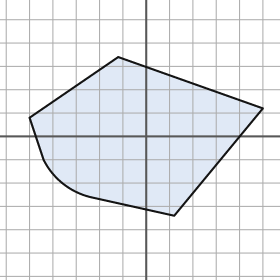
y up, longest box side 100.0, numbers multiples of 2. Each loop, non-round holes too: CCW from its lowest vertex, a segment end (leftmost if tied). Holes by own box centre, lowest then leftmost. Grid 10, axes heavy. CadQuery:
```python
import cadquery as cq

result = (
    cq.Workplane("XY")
    .moveTo(12.0, -34.0)
    .lineTo(50.0, 12.0)
    .lineTo(-12.0, 34.0)
    .lineTo(-50.0, 8.0)
    .lineTo(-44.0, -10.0)
    .threePointArc((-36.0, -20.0), (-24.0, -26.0))
    .close()
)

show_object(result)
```